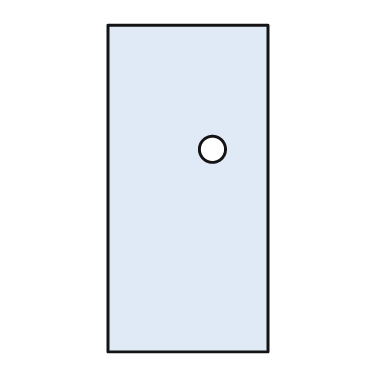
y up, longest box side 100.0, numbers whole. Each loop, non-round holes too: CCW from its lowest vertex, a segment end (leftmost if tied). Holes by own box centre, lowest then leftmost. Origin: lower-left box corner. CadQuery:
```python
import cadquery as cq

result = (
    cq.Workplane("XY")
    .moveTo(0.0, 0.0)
    .lineTo(49.0, 0.0)
    .lineTo(49.0, 100.0)
    .lineTo(0.0, 100.0)
    .close()
    .moveTo(32.0, 62.0)
    .circle(4.0)
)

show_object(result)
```